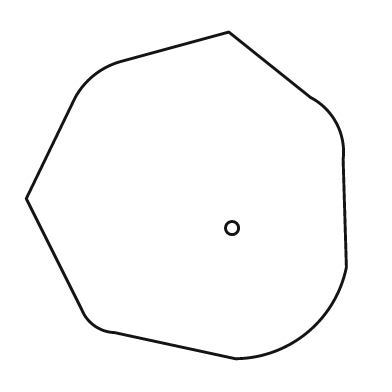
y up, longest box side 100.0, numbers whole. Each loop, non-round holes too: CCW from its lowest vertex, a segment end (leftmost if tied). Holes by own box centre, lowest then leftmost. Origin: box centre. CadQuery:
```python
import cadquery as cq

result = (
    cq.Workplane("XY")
    .moveTo(15.0, -50.0)
    .threePointArc((37.0, -42.0), (49.0, -22.0))
    .lineTo(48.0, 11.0)
    .threePointArc((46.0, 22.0), (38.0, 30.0))
    .lineTo(13.0, 50.0)
    .lineTo(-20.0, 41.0)
    .threePointArc((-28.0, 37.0), (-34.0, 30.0))
    .lineTo(-49.0, -1.0)
    .lineTo(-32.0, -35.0)
    .threePointArc((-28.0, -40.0), (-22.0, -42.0))
    .close()
    .moveTo(14.0, -10.0)
    .circle(2.0)
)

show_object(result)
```